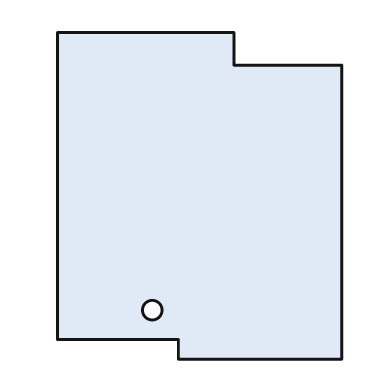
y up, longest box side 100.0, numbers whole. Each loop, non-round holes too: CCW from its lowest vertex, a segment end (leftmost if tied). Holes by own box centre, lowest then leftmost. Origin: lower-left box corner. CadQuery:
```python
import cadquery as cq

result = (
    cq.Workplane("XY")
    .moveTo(37.0, 0.0)
    .lineTo(87.0, 0.0)
    .lineTo(87.0, 90.0)
    .lineTo(54.0, 90.0)
    .lineTo(54.0, 100.0)
    .lineTo(0.0, 100.0)
    .lineTo(0.0, 6.0)
    .lineTo(37.0, 6.0)
    .close()
    .moveTo(29.0, 15.0)
    .circle(3.0)
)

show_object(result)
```